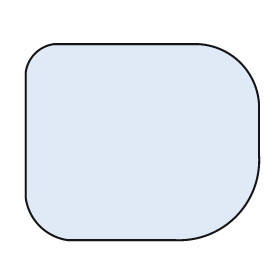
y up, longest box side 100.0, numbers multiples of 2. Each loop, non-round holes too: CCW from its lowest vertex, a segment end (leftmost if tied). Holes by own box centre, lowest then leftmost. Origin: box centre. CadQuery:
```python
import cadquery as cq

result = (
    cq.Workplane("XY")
    .moveTo(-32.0, -42.0)
    .lineTo(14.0, -42.0)
    .threePointArc((40.0, -32.0), (50.0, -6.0))
    .lineTo(50.0, 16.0)
    .threePointArc((42.0, 34.0), (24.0, 42.0))
    .lineTo(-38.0, 42.0)
    .threePointArc((-46.0, 38.0), (-50.0, 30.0))
    .lineTo(-50.0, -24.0)
    .threePointArc((-44.0, -36.0), (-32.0, -42.0))
    .close()
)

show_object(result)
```